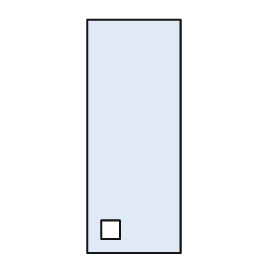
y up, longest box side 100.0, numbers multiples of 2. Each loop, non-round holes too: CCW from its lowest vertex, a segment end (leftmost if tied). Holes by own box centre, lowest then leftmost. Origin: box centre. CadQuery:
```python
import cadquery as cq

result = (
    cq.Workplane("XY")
    .moveTo(-20.0, -50.0)
    .lineTo(20.0, -50.0)
    .lineTo(20.0, 50.0)
    .lineTo(-20.0, 50.0)
    .close()
    .moveTo(-14.0, -44.0)
    .lineTo(-6.0, -44.0)
    .lineTo(-6.0, -36.0)
    .lineTo(-14.0, -36.0)
    .close()
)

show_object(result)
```